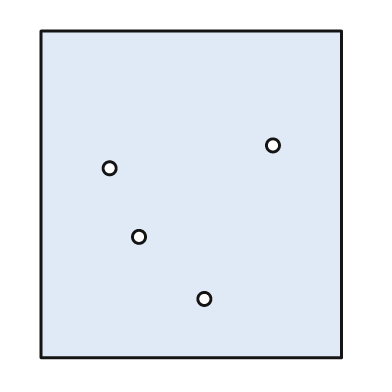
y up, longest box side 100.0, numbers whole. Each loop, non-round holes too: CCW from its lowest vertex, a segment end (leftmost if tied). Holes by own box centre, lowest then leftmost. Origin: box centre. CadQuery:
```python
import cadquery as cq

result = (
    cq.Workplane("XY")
    .moveTo(-46.0, -50.0)
    .lineTo(46.0, -50.0)
    .lineTo(46.0, 50.0)
    .lineTo(-46.0, 50.0)
    .close()
    .moveTo(4.0, -32.0)
    .circle(2.0)
    .moveTo(-16.0, -13.0)
    .circle(2.0)
    .moveTo(-25.0, 8.0)
    .circle(2.0)
    .moveTo(25.0, 15.0)
    .circle(2.0)
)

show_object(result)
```